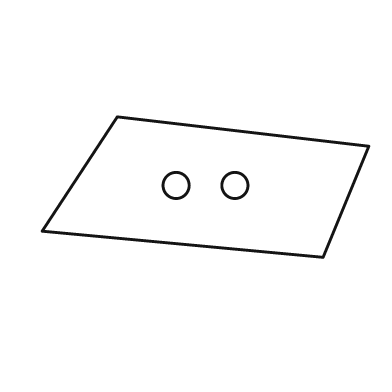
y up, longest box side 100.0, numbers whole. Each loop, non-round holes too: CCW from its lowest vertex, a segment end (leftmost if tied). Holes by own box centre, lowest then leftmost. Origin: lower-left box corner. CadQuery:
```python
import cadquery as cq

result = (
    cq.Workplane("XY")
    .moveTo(86.0, 0.0)
    .lineTo(100.0, 34.0)
    .lineTo(23.0, 43.0)
    .lineTo(0.0, 8.0)
    .close()
    .moveTo(41.0, 22.0)
    .circle(4.0)
    .moveTo(59.0, 22.0)
    .circle(4.0)
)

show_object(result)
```